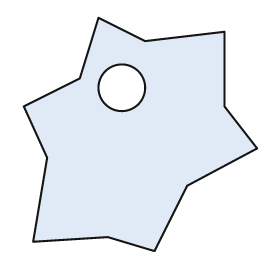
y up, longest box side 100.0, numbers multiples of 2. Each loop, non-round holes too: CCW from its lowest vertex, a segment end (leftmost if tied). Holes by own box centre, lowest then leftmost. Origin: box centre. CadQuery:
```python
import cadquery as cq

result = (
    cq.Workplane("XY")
    .moveTo(6.0, -50.0)
    .lineTo(20.0, -22.0)
    .lineTo(50.0, -6.0)
    .lineTo(36.0, 12.0)
    .lineTo(36.0, 44.0)
    .lineTo(2.0, 40.0)
    .lineTo(-18.0, 50.0)
    .lineTo(-26.0, 24.0)
    .lineTo(-50.0, 12.0)
    .lineTo(-40.0, -10.0)
    .lineTo(-46.0, -46.0)
    .lineTo(-14.0, -44.0)
    .close()
    .moveTo(-8.0, 20.0)
    .circle(10.0)
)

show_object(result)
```